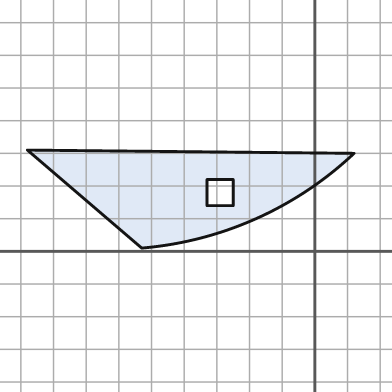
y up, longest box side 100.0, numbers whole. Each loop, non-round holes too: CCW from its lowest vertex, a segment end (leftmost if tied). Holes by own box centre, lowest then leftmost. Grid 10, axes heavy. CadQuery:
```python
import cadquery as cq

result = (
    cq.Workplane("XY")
    .moveTo(-53.0, 1.0)
    .threePointArc((-18.0, 10.0), (12.0, 30.0))
    .lineTo(-88.0, 31.0)
    .close()
    .moveTo(-33.0, 14.0)
    .lineTo(-25.0, 14.0)
    .lineTo(-25.0, 22.0)
    .lineTo(-33.0, 22.0)
    .close()
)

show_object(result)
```